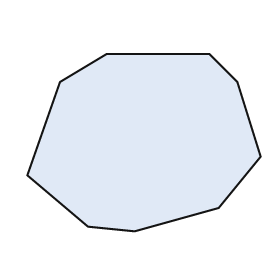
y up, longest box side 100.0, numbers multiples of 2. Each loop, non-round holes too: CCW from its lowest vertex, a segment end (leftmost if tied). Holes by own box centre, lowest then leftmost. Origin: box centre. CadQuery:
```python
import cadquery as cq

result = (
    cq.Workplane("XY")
    .moveTo(-4.0, -38.0)
    .lineTo(32.0, -28.0)
    .lineTo(50.0, -6.0)
    .lineTo(40.0, 26.0)
    .lineTo(28.0, 38.0)
    .lineTo(-16.0, 38.0)
    .lineTo(-36.0, 26.0)
    .lineTo(-50.0, -14.0)
    .lineTo(-24.0, -36.0)
    .close()
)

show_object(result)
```